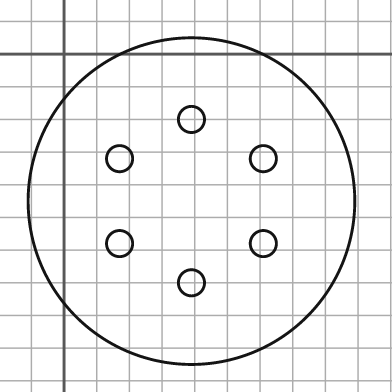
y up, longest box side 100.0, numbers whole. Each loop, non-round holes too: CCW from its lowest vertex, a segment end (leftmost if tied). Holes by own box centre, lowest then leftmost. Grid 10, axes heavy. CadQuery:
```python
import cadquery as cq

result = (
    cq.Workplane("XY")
    .moveTo(39.0, -45.0)
    .circle(50.0)
    .moveTo(39.0, -70.0)
    .circle(4.0)
    .moveTo(17.0, -58.0)
    .circle(4.0)
    .moveTo(61.0, -58.0)
    .circle(4.0)
    .moveTo(17.0, -32.0)
    .circle(4.0)
    .moveTo(61.0, -32.0)
    .circle(4.0)
    .moveTo(39.0, -20.0)
    .circle(4.0)
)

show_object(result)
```